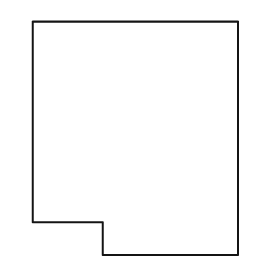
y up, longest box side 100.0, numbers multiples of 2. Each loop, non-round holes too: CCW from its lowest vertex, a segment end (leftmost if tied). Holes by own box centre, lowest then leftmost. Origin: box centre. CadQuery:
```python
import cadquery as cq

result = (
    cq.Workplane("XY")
    .moveTo(-14.0, -50.0)
    .lineTo(44.0, -50.0)
    .lineTo(44.0, 50.0)
    .lineTo(-44.0, 50.0)
    .lineTo(-44.0, -36.0)
    .lineTo(-14.0, -36.0)
    .close()
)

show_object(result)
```